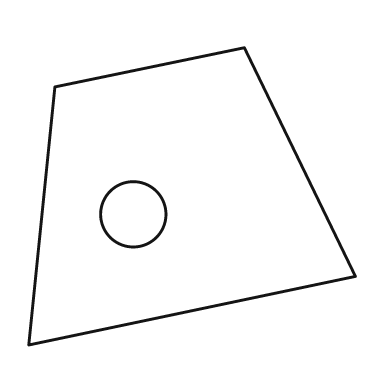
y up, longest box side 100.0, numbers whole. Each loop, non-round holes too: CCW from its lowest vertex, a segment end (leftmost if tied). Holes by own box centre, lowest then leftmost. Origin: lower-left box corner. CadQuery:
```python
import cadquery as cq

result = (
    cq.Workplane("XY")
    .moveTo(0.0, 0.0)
    .lineTo(100.0, 21.0)
    .lineTo(66.0, 91.0)
    .lineTo(8.0, 79.0)
    .close()
    .moveTo(32.0, 40.0)
    .circle(10.0)
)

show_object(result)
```